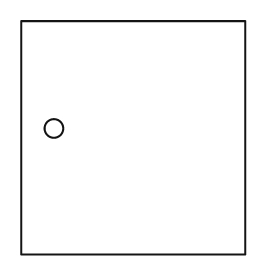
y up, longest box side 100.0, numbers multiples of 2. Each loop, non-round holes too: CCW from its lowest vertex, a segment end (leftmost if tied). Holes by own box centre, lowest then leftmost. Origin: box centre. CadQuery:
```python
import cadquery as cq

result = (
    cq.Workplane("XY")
    .moveTo(-48.0, -50.0)
    .lineTo(48.0, -50.0)
    .lineTo(48.0, 50.0)
    .lineTo(-48.0, 50.0)
    .close()
    .moveTo(-34.0, 4.0)
    .circle(4.0)
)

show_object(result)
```